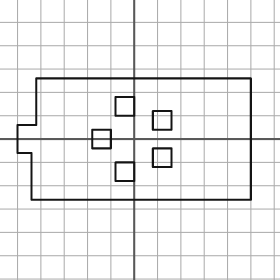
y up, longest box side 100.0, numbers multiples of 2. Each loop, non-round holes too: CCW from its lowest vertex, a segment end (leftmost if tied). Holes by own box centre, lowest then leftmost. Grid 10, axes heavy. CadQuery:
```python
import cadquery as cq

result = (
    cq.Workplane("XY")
    .moveTo(-44.0, -26.0)
    .lineTo(50.0, -26.0)
    .lineTo(50.0, 26.0)
    .lineTo(-42.0, 26.0)
    .lineTo(-42.0, 6.0)
    .lineTo(-50.0, 6.0)
    .lineTo(-50.0, -6.0)
    .lineTo(-44.0, -6.0)
    .close()
    .moveTo(-8.0, -18.0)
    .lineTo(0.0, -18.0)
    .lineTo(0.0, -10.0)
    .lineTo(-8.0, -10.0)
    .close()
    .moveTo(8.0, -12.0)
    .lineTo(16.0, -12.0)
    .lineTo(16.0, -4.0)
    .lineTo(8.0, -4.0)
    .close()
    .moveTo(-18.0, -4.0)
    .lineTo(-10.0, -4.0)
    .lineTo(-10.0, 4.0)
    .lineTo(-18.0, 4.0)
    .close()
    .moveTo(8.0, 4.0)
    .lineTo(16.0, 4.0)
    .lineTo(16.0, 12.0)
    .lineTo(8.0, 12.0)
    .close()
    .moveTo(-8.0, 10.0)
    .lineTo(0.0, 10.0)
    .lineTo(0.0, 18.0)
    .lineTo(-8.0, 18.0)
    .close()
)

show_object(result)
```